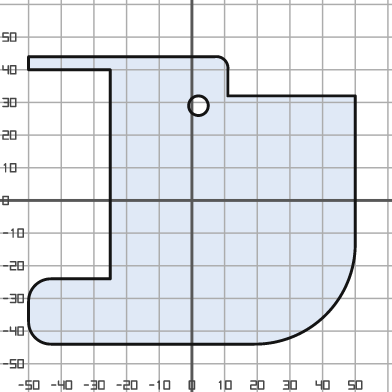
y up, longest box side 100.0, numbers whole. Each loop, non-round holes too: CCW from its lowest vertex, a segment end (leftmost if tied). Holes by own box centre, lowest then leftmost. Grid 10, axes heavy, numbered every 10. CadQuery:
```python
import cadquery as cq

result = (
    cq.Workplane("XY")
    .moveTo(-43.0, -44.0)
    .lineTo(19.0, -44.0)
    .threePointArc((41.0, -35.0), (50.0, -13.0))
    .lineTo(50.0, 32.0)
    .lineTo(11.0, 32.0)
    .lineTo(11.0, 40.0)
    .threePointArc((10.0, 43.0), (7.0, 44.0))
    .lineTo(-50.0, 44.0)
    .lineTo(-50.0, 40.0)
    .lineTo(-25.0, 40.0)
    .lineTo(-25.0, -24.0)
    .lineTo(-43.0, -24.0)
    .threePointArc((-48.0, -26.0), (-50.0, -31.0))
    .lineTo(-50.0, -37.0)
    .threePointArc((-48.0, -42.0), (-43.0, -44.0))
    .close()
    .moveTo(2.0, 29.0)
    .circle(3.0)
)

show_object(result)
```